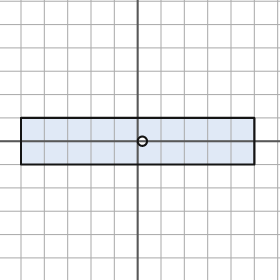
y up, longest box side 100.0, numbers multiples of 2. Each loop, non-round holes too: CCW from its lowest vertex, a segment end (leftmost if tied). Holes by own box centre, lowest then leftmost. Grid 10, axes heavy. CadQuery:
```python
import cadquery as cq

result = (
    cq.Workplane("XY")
    .moveTo(-50.0, -10.0)
    .lineTo(50.0, -10.0)
    .lineTo(50.0, 10.0)
    .lineTo(-50.0, 10.0)
    .close()
    .moveTo(2.0, 0.0)
    .circle(2.0)
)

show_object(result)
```